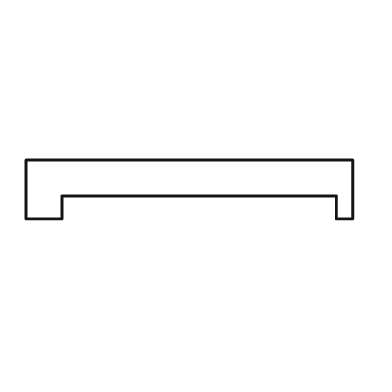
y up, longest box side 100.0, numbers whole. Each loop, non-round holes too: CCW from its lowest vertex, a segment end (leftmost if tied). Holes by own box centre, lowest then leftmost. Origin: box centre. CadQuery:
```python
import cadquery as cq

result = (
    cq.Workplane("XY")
    .moveTo(-50.0, -9.0)
    .lineTo(-39.0, -9.0)
    .lineTo(-39.0, -2.0)
    .lineTo(45.0, -2.0)
    .lineTo(45.0, -9.0)
    .lineTo(50.0, -9.0)
    .lineTo(50.0, 9.0)
    .lineTo(-50.0, 9.0)
    .close()
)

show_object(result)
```